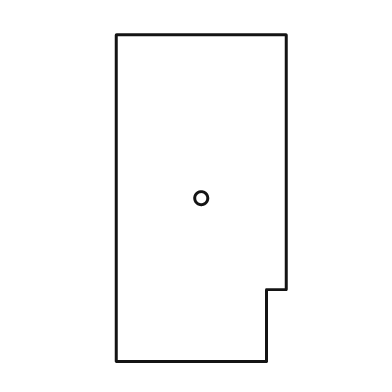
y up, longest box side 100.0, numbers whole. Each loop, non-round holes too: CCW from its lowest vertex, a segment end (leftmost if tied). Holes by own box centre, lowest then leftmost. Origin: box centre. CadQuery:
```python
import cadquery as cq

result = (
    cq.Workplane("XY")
    .moveTo(-26.0, -50.0)
    .lineTo(20.0, -50.0)
    .lineTo(20.0, -28.0)
    .lineTo(26.0, -28.0)
    .lineTo(26.0, 50.0)
    .lineTo(-26.0, 50.0)
    .close()
    .moveTo(0.0, 0.0)
    .circle(2.0)
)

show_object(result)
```